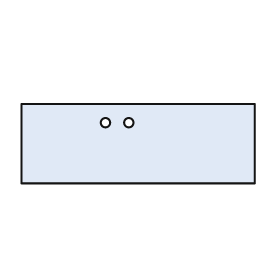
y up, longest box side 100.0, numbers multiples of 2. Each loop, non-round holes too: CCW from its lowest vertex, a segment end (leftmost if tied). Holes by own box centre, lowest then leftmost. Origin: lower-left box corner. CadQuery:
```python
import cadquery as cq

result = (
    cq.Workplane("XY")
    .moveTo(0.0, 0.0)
    .lineTo(100.0, 0.0)
    .lineTo(100.0, 34.0)
    .lineTo(0.0, 34.0)
    .close()
    .moveTo(36.0, 26.0)
    .circle(2.0)
    .moveTo(46.0, 26.0)
    .circle(2.0)
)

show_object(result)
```